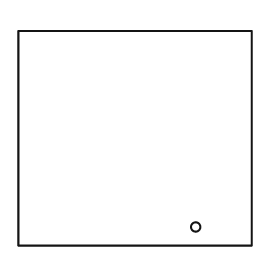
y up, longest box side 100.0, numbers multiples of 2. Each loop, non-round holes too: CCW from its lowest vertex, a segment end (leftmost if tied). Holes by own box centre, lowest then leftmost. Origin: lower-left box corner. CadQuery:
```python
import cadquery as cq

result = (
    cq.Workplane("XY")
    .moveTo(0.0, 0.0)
    .lineTo(100.0, 0.0)
    .lineTo(100.0, 92.0)
    .lineTo(0.0, 92.0)
    .close()
    .moveTo(76.0, 8.0)
    .circle(2.0)
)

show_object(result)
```